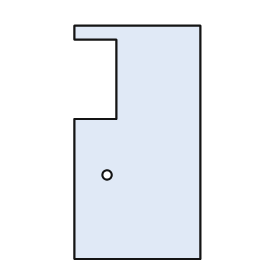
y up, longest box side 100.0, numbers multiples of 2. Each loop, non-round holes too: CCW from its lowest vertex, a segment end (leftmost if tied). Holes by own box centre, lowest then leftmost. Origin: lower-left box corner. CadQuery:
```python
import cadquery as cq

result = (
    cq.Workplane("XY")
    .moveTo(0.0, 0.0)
    .lineTo(54.0, 0.0)
    .lineTo(54.0, 100.0)
    .lineTo(0.0, 100.0)
    .lineTo(0.0, 94.0)
    .lineTo(18.0, 94.0)
    .lineTo(18.0, 60.0)
    .lineTo(0.0, 60.0)
    .close()
    .moveTo(14.0, 36.0)
    .circle(2.0)
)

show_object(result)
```